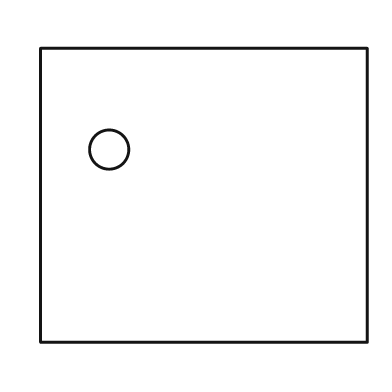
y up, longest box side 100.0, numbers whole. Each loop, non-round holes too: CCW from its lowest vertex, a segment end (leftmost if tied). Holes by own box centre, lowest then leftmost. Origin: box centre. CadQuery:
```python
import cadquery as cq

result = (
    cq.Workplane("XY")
    .moveTo(-50.0, -45.0)
    .lineTo(50.0, -45.0)
    .lineTo(50.0, 45.0)
    .lineTo(-50.0, 45.0)
    .close()
    .moveTo(-29.0, 14.0)
    .circle(6.0)
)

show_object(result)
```